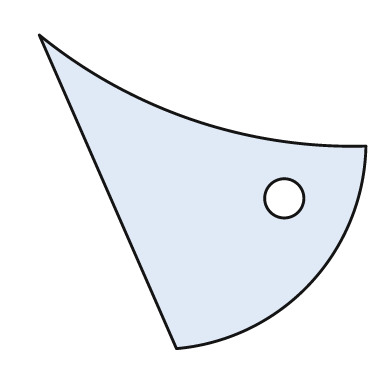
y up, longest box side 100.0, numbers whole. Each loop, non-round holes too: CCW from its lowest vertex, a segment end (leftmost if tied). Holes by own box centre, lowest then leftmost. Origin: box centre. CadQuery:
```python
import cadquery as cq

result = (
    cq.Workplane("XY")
    .moveTo(-8.0, -48.0)
    .threePointArc((33.0, -28.0), (50.0, 14.0))
    .threePointArc((-3.0, 22.0), (-50.0, 48.0))
    .close()
    .moveTo(25.0, -2.0)
    .circle(6.0)
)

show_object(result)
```